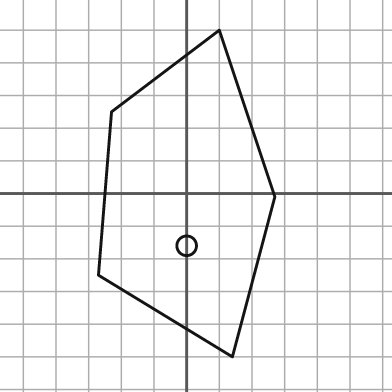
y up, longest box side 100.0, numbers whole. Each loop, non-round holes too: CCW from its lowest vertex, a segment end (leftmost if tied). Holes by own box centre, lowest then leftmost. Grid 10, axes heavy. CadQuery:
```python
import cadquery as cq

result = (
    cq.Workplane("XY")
    .moveTo(14.0, -50.0)
    .lineTo(27.0, -1.0)
    .lineTo(10.0, 50.0)
    .lineTo(-23.0, 25.0)
    .lineTo(-27.0, -25.0)
    .close()
    .moveTo(0.0, -16.0)
    .circle(3.0)
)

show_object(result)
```